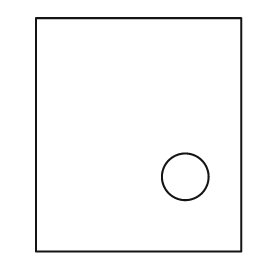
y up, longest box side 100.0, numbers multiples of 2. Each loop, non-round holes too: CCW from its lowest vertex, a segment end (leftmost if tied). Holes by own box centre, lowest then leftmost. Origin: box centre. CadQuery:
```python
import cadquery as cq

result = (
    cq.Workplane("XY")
    .moveTo(-44.0, -50.0)
    .lineTo(44.0, -50.0)
    .lineTo(44.0, 50.0)
    .lineTo(-44.0, 50.0)
    .close()
    .moveTo(20.0, -18.0)
    .circle(10.0)
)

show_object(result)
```